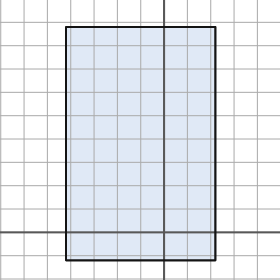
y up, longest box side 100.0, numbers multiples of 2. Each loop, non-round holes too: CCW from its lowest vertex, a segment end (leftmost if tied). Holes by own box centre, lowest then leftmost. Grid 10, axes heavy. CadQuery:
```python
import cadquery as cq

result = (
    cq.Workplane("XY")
    .moveTo(-42.0, -12.0)
    .lineTo(22.0, -12.0)
    .lineTo(22.0, 88.0)
    .lineTo(-42.0, 88.0)
    .close()
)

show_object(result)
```